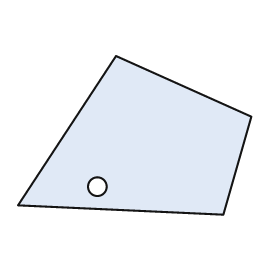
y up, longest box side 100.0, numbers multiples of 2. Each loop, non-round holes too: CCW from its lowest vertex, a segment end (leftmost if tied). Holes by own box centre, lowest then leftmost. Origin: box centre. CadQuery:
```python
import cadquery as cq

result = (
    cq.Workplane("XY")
    .moveTo(38.0, -34.0)
    .lineTo(50.0, 8.0)
    .lineTo(-8.0, 34.0)
    .lineTo(-50.0, -30.0)
    .close()
    .moveTo(-16.0, -22.0)
    .circle(4.0)
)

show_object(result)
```